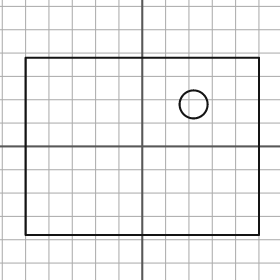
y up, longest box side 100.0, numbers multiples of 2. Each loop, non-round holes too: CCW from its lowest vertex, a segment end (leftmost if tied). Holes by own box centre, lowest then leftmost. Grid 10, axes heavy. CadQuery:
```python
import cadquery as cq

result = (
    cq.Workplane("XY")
    .moveTo(-50.0, -38.0)
    .lineTo(50.0, -38.0)
    .lineTo(50.0, 38.0)
    .lineTo(-50.0, 38.0)
    .close()
    .moveTo(22.0, 18.0)
    .circle(6.0)
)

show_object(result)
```